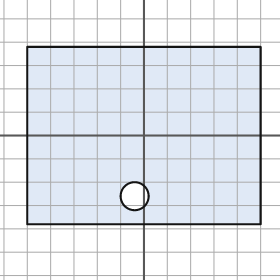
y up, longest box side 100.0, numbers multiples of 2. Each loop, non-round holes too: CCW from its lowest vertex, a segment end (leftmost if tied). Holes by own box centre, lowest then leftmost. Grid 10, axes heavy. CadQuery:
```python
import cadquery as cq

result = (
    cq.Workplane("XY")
    .moveTo(-50.0, -38.0)
    .lineTo(50.0, -38.0)
    .lineTo(50.0, 38.0)
    .lineTo(-50.0, 38.0)
    .close()
    .moveTo(-4.0, -26.0)
    .circle(6.0)
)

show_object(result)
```